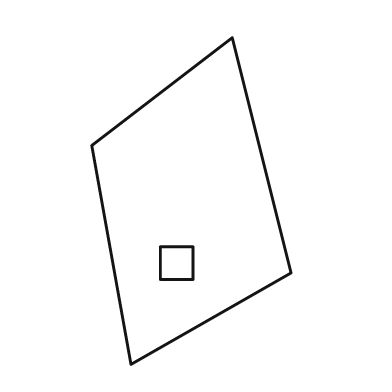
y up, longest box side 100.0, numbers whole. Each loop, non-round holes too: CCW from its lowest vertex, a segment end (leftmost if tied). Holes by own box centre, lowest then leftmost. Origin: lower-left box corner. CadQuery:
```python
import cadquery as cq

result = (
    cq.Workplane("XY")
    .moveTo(12.0, 0.0)
    .lineTo(61.0, 28.0)
    .lineTo(43.0, 100.0)
    .lineTo(0.0, 67.0)
    .close()
    .moveTo(21.0, 26.0)
    .lineTo(31.0, 26.0)
    .lineTo(31.0, 36.0)
    .lineTo(21.0, 36.0)
    .close()
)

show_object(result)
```